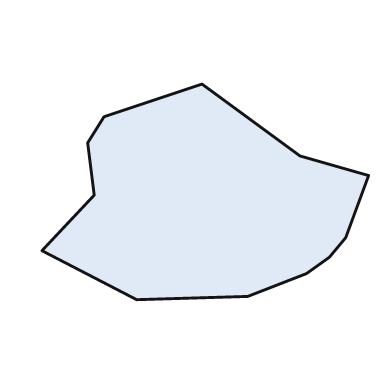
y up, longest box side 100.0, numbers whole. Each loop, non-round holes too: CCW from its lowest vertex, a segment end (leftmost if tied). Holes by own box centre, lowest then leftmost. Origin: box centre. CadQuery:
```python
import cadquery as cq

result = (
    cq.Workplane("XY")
    .moveTo(-21.0, -33.0)
    .lineTo(13.0, -32.0)
    .lineTo(31.0, -25.0)
    .lineTo(38.0, -20.0)
    .lineTo(43.0, -14.0)
    .lineTo(50.0, 5.0)
    .lineTo(29.0, 11.0)
    .lineTo(-1.0, 33.0)
    .lineTo(-31.0, 23.0)
    .lineTo(-36.0, 15.0)
    .lineTo(-34.0, -1.0)
    .lineTo(-50.0, -18.0)
    .close()
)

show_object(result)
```